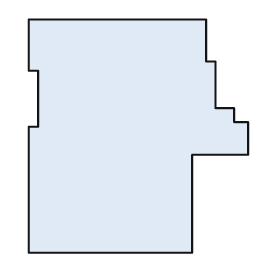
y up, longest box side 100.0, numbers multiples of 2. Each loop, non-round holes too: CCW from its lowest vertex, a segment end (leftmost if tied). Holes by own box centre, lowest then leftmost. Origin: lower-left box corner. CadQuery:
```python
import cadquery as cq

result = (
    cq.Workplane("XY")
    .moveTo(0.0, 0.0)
    .lineTo(70.0, 0.0)
    .lineTo(70.0, 42.0)
    .lineTo(94.0, 42.0)
    .lineTo(94.0, 56.0)
    .lineTo(88.0, 56.0)
    .lineTo(88.0, 62.0)
    .lineTo(80.0, 62.0)
    .lineTo(80.0, 82.0)
    .lineTo(76.0, 82.0)
    .lineTo(76.0, 100.0)
    .lineTo(0.0, 100.0)
    .lineTo(0.0, 78.0)
    .lineTo(4.0, 78.0)
    .lineTo(4.0, 54.0)
    .lineTo(0.0, 54.0)
    .close()
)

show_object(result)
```